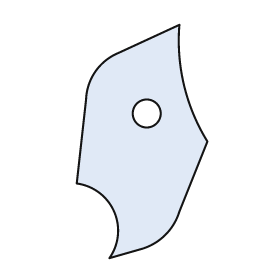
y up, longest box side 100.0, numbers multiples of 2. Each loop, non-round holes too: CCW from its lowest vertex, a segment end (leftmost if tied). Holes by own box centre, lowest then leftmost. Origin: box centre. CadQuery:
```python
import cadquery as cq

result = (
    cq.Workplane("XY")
    .moveTo(-14.0, -50.0)
    .lineTo(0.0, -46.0)
    .threePointArc((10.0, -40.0), (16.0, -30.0))
    .lineTo(28.0, 0.0)
    .threePointArc((18.0, 24.0), (16.0, 50.0))
    .lineTo(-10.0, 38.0)
    .threePointArc((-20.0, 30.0), (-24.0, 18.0))
    .lineTo(-28.0, -18.0)
    .threePointArc((-12.0, -30.0), (-14.0, -50.0))
    .close()
    .moveTo(2.0, 12.0)
    .circle(6.0)
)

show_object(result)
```